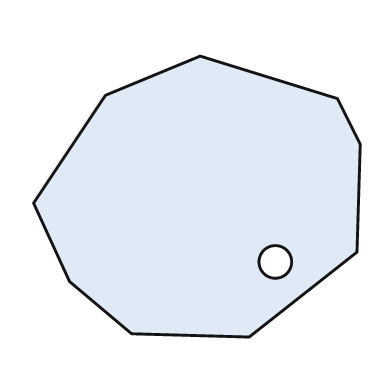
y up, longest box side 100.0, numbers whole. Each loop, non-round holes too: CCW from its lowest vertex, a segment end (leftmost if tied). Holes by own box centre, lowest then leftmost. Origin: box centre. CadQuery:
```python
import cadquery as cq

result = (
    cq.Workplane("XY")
    .moveTo(16.0, -43.0)
    .lineTo(49.0, -17.0)
    .lineTo(50.0, 16.0)
    .lineTo(43.0, 30.0)
    .lineTo(1.0, 43.0)
    .lineTo(-28.0, 31.0)
    .lineTo(-50.0, -2.0)
    .lineTo(-39.0, -26.0)
    .lineTo(-20.0, -42.0)
    .close()
    .moveTo(24.0, -20.0)
    .circle(5.0)
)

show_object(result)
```